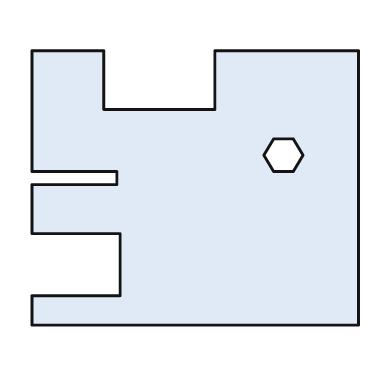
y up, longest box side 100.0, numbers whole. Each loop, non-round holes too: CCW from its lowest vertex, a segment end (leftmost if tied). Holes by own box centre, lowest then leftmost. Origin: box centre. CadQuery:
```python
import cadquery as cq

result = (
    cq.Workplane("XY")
    .moveTo(-50.0, -42.0)
    .lineTo(50.0, -42.0)
    .lineTo(50.0, 42.0)
    .lineTo(6.0, 42.0)
    .lineTo(6.0, 24.0)
    .lineTo(-28.0, 24.0)
    .lineTo(-28.0, 42.0)
    .lineTo(-50.0, 42.0)
    .lineTo(-50.0, 5.0)
    .lineTo(-24.0, 5.0)
    .lineTo(-24.0, 1.0)
    .lineTo(-50.0, 1.0)
    .lineTo(-50.0, -14.0)
    .lineTo(-23.0, -14.0)
    .lineTo(-23.0, -33.0)
    .lineTo(-50.0, -33.0)
    .close()
    .moveTo(24.0, 5.0)
    .lineTo(30.0, 5.0)
    .lineTo(33.0, 10.0)
    .lineTo(30.0, 15.0)
    .lineTo(24.0, 15.0)
    .lineTo(21.0, 10.0)
    .close()
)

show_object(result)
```